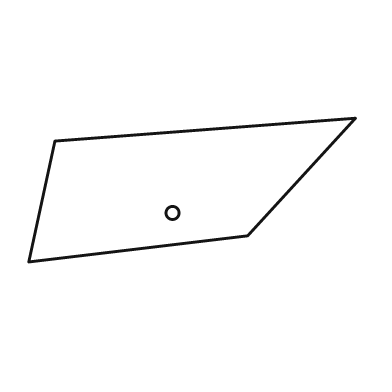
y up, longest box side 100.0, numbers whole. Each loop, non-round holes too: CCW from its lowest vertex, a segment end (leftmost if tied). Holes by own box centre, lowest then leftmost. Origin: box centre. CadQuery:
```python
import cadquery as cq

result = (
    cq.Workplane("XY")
    .moveTo(-50.0, -22.0)
    .lineTo(17.0, -14.0)
    .lineTo(50.0, 22.0)
    .lineTo(-42.0, 15.0)
    .close()
    .moveTo(-6.0, -7.0)
    .circle(2.0)
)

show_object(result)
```